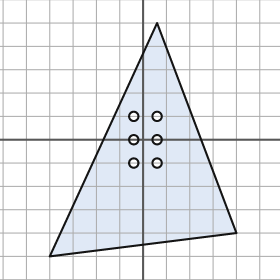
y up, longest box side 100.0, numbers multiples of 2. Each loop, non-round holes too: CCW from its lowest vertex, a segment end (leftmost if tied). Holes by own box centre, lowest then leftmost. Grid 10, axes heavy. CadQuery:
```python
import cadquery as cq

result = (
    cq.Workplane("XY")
    .moveTo(-40.0, -50.0)
    .lineTo(40.0, -40.0)
    .lineTo(6.0, 50.0)
    .close()
    .moveTo(-4.0, -10.0)
    .circle(2.0)
    .moveTo(6.0, -10.0)
    .circle(2.0)
    .moveTo(-4.0, 0.0)
    .circle(2.0)
    .moveTo(6.0, 0.0)
    .circle(2.0)
    .moveTo(-4.0, 10.0)
    .circle(2.0)
    .moveTo(6.0, 10.0)
    .circle(2.0)
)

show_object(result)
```